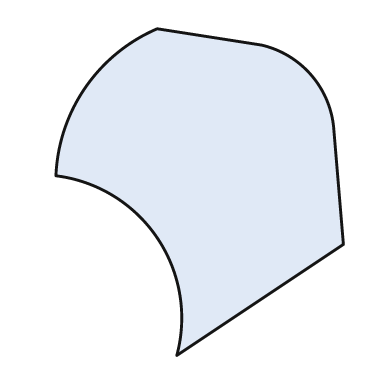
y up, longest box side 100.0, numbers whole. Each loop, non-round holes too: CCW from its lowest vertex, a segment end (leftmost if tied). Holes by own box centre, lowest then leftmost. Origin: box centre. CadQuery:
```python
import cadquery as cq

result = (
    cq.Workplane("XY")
    .moveTo(-7.0, -50.0)
    .lineTo(44.0, -16.0)
    .lineTo(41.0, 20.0)
    .threePointArc((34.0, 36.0), (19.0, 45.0))
    .lineTo(-13.0, 50.0)
    .threePointArc((-35.0, 32.0), (-44.0, 5.0))
    .threePointArc((-13.0, -14.0), (-7.0, -50.0))
    .close()
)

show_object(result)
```